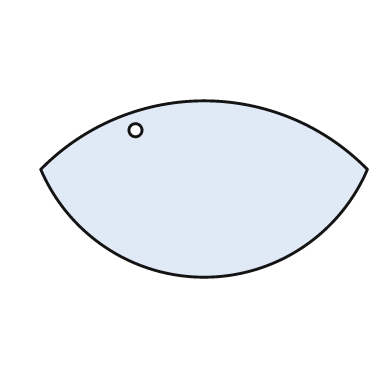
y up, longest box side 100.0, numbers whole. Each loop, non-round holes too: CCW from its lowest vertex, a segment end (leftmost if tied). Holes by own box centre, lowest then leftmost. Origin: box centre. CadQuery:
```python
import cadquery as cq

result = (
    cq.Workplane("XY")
    .moveTo(-50.0, 6.0)
    .threePointArc((0.0, -27.0), (50.0, 6.0))
    .threePointArc((0.0, 27.0), (-50.0, 6.0))
    .close()
    .moveTo(-21.0, 18.0)
    .circle(2.0)
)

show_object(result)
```